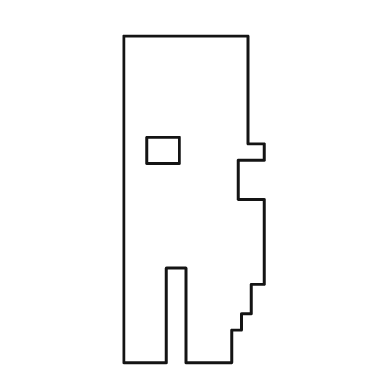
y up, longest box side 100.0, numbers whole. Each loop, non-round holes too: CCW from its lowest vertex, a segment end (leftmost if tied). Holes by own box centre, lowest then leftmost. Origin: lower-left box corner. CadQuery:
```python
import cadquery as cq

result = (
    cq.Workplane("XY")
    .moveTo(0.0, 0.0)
    .lineTo(13.0, 0.0)
    .lineTo(13.0, 29.0)
    .lineTo(19.0, 29.0)
    .lineTo(19.0, 0.0)
    .lineTo(33.0, 0.0)
    .lineTo(33.0, 10.0)
    .lineTo(36.0, 10.0)
    .lineTo(36.0, 15.0)
    .lineTo(39.0, 15.0)
    .lineTo(39.0, 24.0)
    .lineTo(43.0, 24.0)
    .lineTo(43.0, 50.0)
    .lineTo(35.0, 50.0)
    .lineTo(35.0, 62.0)
    .lineTo(43.0, 62.0)
    .lineTo(43.0, 67.0)
    .lineTo(38.0, 67.0)
    .lineTo(38.0, 100.0)
    .lineTo(0.0, 100.0)
    .close()
    .moveTo(7.0, 61.0)
    .lineTo(17.0, 61.0)
    .lineTo(17.0, 69.0)
    .lineTo(7.0, 69.0)
    .close()
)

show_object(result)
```